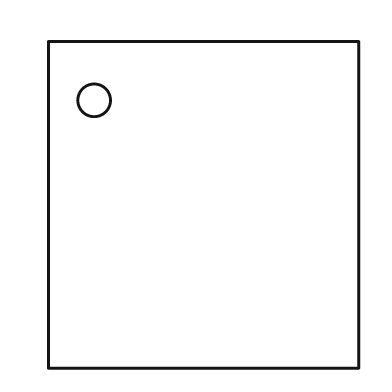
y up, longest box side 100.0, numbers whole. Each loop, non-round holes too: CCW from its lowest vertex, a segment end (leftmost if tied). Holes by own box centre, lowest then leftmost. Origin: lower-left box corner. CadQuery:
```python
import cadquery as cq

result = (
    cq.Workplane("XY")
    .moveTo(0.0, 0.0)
    .lineTo(95.0, 0.0)
    .lineTo(95.0, 100.0)
    .lineTo(0.0, 100.0)
    .close()
    .moveTo(14.0, 82.0)
    .circle(5.0)
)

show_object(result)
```